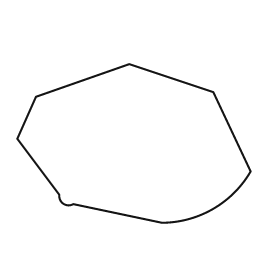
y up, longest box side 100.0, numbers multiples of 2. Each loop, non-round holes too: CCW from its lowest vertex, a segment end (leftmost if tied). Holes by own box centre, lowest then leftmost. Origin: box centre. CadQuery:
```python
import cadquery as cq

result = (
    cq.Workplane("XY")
    .moveTo(12.0, -34.0)
    .threePointArc((34.0, -28.0), (50.0, -12.0))
    .lineTo(34.0, 22.0)
    .lineTo(-2.0, 34.0)
    .lineTo(-42.0, 20.0)
    .lineTo(-50.0, 2.0)
    .lineTo(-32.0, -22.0)
    .threePointArc((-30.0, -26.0), (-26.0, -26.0))
    .close()
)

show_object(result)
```